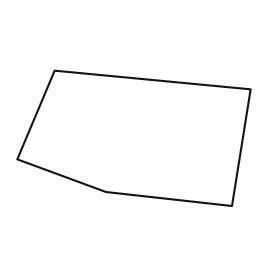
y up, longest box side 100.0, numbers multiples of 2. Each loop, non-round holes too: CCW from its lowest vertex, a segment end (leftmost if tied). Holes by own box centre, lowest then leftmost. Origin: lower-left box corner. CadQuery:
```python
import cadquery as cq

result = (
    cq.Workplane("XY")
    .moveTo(92.0, 0.0)
    .lineTo(100.0, 50.0)
    .lineTo(16.0, 58.0)
    .lineTo(0.0, 20.0)
    .lineTo(38.0, 6.0)
    .close()
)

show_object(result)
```